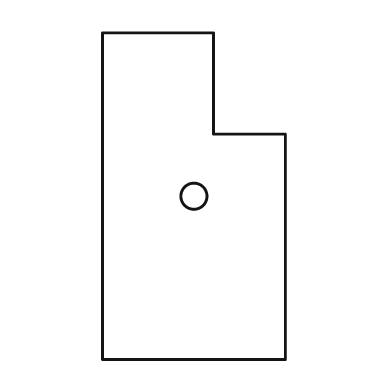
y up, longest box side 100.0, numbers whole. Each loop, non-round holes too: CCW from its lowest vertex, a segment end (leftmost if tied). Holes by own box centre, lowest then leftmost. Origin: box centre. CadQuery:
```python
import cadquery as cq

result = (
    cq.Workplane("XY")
    .moveTo(-28.0, -50.0)
    .lineTo(28.0, -50.0)
    .lineTo(28.0, 19.0)
    .lineTo(6.0, 19.0)
    .lineTo(6.0, 50.0)
    .lineTo(-28.0, 50.0)
    .close()
    .moveTo(0.0, 0.0)
    .circle(4.0)
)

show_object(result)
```